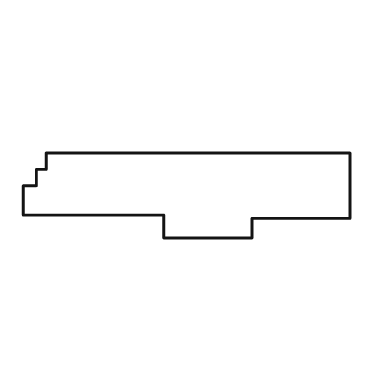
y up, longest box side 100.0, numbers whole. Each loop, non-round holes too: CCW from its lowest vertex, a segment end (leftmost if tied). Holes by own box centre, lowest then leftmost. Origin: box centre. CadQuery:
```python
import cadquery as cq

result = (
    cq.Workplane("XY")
    .moveTo(-7.0, -13.0)
    .lineTo(20.0, -13.0)
    .lineTo(20.0, -7.0)
    .lineTo(50.0, -7.0)
    .lineTo(50.0, 13.0)
    .lineTo(-43.0, 13.0)
    .lineTo(-43.0, 8.0)
    .lineTo(-46.0, 8.0)
    .lineTo(-46.0, 3.0)
    .lineTo(-50.0, 3.0)
    .lineTo(-50.0, -6.0)
    .lineTo(-7.0, -6.0)
    .close()
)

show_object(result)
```